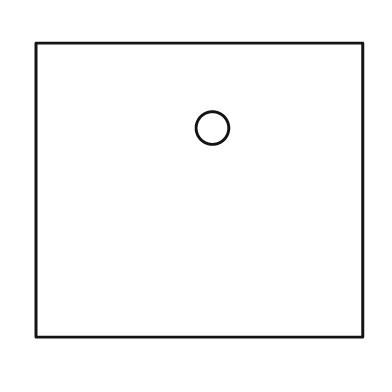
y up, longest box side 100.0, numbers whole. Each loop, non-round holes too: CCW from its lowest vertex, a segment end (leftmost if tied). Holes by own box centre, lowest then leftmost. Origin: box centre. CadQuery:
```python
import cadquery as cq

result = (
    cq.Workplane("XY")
    .moveTo(-50.0, -45.0)
    .lineTo(50.0, -45.0)
    .lineTo(50.0, 45.0)
    .lineTo(-50.0, 45.0)
    .close()
    .moveTo(4.0, 19.0)
    .circle(5.0)
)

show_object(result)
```